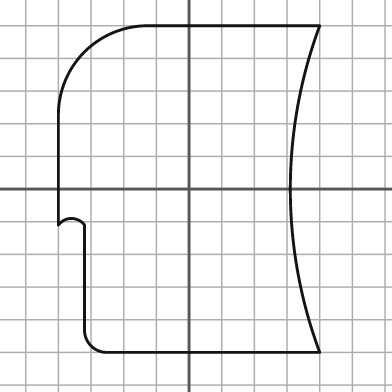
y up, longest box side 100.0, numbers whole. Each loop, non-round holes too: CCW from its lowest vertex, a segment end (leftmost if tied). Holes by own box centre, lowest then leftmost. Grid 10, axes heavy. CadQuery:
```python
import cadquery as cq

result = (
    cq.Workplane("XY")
    .moveTo(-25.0, -50.0)
    .lineTo(40.0, -50.0)
    .threePointArc((31.0, 0.0), (40.0, 50.0))
    .lineTo(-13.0, 50.0)
    .threePointArc((-32.0, 42.0), (-40.0, 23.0))
    .lineTo(-40.0, -11.0)
    .threePointArc((-36.0, -9.0), (-32.0, -11.0))
    .lineTo(-32.0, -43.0)
    .threePointArc((-30.0, -48.0), (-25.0, -50.0))
    .close()
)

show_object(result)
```